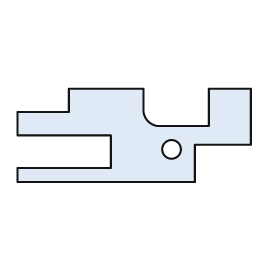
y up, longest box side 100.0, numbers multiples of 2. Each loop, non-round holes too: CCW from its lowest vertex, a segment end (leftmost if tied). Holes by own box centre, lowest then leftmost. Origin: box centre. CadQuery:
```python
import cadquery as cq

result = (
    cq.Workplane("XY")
    .moveTo(-50.0, -20.0)
    .lineTo(26.0, -20.0)
    .lineTo(26.0, -4.0)
    .lineTo(50.0, -4.0)
    .lineTo(50.0, 20.0)
    .lineTo(32.0, 20.0)
    .lineTo(32.0, 4.0)
    .lineTo(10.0, 4.0)
    .threePointArc((6.0, 6.0), (4.0, 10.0))
    .lineTo(4.0, 20.0)
    .lineTo(-28.0, 20.0)
    .lineTo(-28.0, 10.0)
    .lineTo(-50.0, 10.0)
    .lineTo(-50.0, 0.0)
    .lineTo(-10.0, 0.0)
    .lineTo(-10.0, -14.0)
    .lineTo(-50.0, -14.0)
    .close()
    .moveTo(16.0, -6.0)
    .circle(4.0)
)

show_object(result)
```